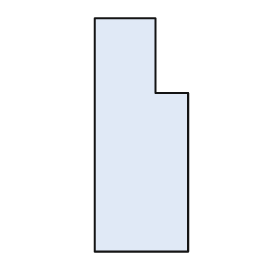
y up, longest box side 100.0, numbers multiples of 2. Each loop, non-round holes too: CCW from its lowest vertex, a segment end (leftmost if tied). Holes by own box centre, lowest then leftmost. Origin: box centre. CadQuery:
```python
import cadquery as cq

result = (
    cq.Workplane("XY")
    .moveTo(-20.0, -50.0)
    .lineTo(20.0, -50.0)
    .lineTo(20.0, 18.0)
    .lineTo(6.0, 18.0)
    .lineTo(6.0, 50.0)
    .lineTo(-20.0, 50.0)
    .close()
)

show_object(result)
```